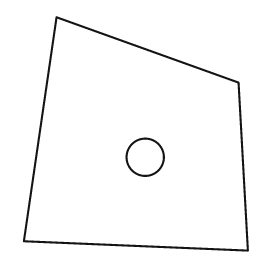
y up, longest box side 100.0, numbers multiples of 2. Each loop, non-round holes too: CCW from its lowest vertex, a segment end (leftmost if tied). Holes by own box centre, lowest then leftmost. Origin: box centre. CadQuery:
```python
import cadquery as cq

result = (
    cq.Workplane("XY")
    .moveTo(48.0, -50.0)
    .lineTo(44.0, 22.0)
    .lineTo(-34.0, 50.0)
    .lineTo(-48.0, -46.0)
    .close()
    .moveTo(4.0, -10.0)
    .circle(8.0)
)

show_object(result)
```